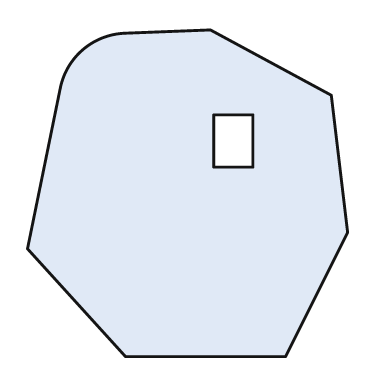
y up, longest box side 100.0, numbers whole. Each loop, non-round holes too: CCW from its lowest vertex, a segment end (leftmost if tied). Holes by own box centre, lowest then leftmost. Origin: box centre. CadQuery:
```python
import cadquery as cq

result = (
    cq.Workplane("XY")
    .moveTo(-19.0, -50.0)
    .lineTo(30.0, -50.0)
    .lineTo(49.0, -12.0)
    .lineTo(44.0, 30.0)
    .lineTo(7.0, 50.0)
    .lineTo(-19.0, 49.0)
    .threePointArc((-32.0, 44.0), (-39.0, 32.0))
    .lineTo(-49.0, -17.0)
    .close()
    .moveTo(8.0, 8.0)
    .lineTo(20.0, 8.0)
    .lineTo(20.0, 24.0)
    .lineTo(8.0, 24.0)
    .close()
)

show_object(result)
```